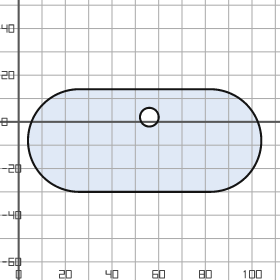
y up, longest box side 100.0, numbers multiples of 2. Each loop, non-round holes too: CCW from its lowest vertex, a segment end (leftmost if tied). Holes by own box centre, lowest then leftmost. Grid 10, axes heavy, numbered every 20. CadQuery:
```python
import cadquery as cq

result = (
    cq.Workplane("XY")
    .moveTo(26.0, -30.0)
    .lineTo(82.0, -30.0)
    .threePointArc((104.0, -8.0), (82.0, 14.0))
    .lineTo(26.0, 14.0)
    .threePointArc((4.0, -8.0), (26.0, -30.0))
    .close()
    .moveTo(56.0, 2.0)
    .circle(4.0)
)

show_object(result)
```